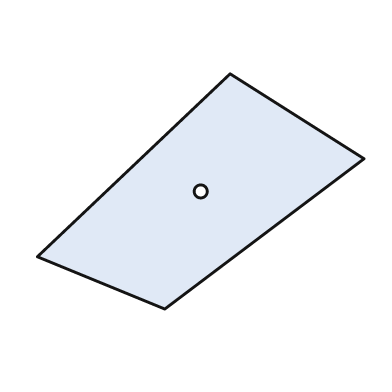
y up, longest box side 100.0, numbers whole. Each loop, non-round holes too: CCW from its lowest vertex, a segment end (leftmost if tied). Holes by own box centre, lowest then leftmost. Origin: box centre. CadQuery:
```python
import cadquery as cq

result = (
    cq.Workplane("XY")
    .moveTo(-11.0, -36.0)
    .lineTo(50.0, 10.0)
    .lineTo(9.0, 36.0)
    .lineTo(-50.0, -20.0)
    .close()
    .moveTo(0.0, 0.0)
    .circle(2.0)
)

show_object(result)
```